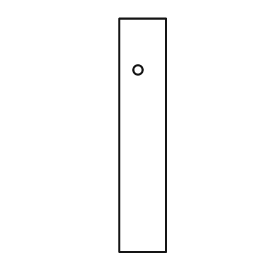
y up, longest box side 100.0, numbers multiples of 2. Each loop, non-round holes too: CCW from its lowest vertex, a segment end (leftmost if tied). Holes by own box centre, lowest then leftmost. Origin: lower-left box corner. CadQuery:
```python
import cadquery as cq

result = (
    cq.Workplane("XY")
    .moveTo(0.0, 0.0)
    .lineTo(20.0, 0.0)
    .lineTo(20.0, 100.0)
    .lineTo(0.0, 100.0)
    .close()
    .moveTo(8.0, 78.0)
    .circle(2.0)
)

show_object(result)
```